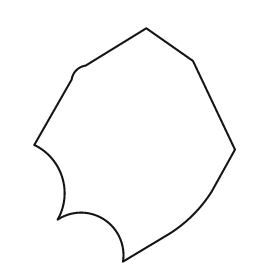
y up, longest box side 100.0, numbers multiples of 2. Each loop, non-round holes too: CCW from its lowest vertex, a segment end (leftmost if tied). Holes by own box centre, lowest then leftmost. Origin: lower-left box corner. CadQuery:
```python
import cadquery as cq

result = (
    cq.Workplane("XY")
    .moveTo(38.0, 0.0)
    .lineTo(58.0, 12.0)
    .threePointArc((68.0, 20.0), (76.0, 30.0))
    .lineTo(86.0, 48.0)
    .lineTo(68.0, 86.0)
    .lineTo(48.0, 100.0)
    .lineTo(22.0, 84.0)
    .threePointArc((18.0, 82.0), (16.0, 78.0))
    .lineTo(0.0, 50.0)
    .threePointArc((12.0, 36.0), (10.0, 18.0))
    .threePointArc((30.0, 18.0), (38.0, 0.0))
    .close()
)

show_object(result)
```